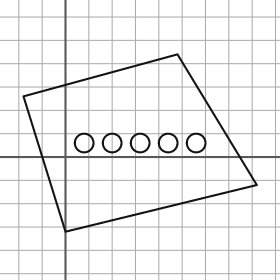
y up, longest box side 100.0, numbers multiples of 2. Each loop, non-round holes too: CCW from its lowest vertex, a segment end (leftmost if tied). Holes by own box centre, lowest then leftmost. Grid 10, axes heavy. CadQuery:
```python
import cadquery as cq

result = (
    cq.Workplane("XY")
    .moveTo(0.0, -32.0)
    .lineTo(82.0, -12.0)
    .lineTo(48.0, 44.0)
    .lineTo(-18.0, 26.0)
    .close()
    .moveTo(8.0, 6.0)
    .circle(4.0)
    .moveTo(20.0, 6.0)
    .circle(4.0)
    .moveTo(32.0, 6.0)
    .circle(4.0)
    .moveTo(44.0, 6.0)
    .circle(4.0)
    .moveTo(56.0, 6.0)
    .circle(4.0)
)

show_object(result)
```